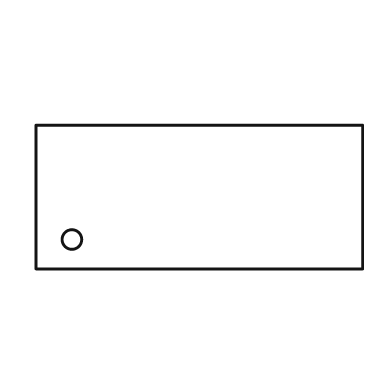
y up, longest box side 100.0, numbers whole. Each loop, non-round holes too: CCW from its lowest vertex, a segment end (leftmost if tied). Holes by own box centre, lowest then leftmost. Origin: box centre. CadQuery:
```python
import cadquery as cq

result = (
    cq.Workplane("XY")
    .moveTo(-50.0, -22.0)
    .lineTo(50.0, -22.0)
    .lineTo(50.0, 22.0)
    .lineTo(-50.0, 22.0)
    .close()
    .moveTo(-39.0, -13.0)
    .circle(3.0)
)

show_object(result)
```